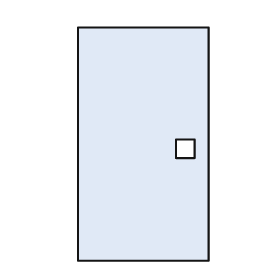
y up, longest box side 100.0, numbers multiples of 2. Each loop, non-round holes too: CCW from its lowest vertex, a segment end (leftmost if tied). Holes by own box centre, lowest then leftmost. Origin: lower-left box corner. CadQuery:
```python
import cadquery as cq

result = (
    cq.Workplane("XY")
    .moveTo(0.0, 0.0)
    .lineTo(56.0, 0.0)
    .lineTo(56.0, 100.0)
    .lineTo(0.0, 100.0)
    .close()
    .moveTo(42.0, 44.0)
    .lineTo(50.0, 44.0)
    .lineTo(50.0, 52.0)
    .lineTo(42.0, 52.0)
    .close()
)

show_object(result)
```